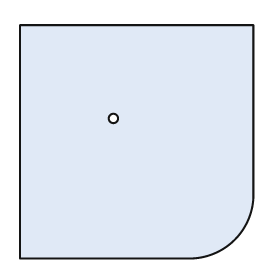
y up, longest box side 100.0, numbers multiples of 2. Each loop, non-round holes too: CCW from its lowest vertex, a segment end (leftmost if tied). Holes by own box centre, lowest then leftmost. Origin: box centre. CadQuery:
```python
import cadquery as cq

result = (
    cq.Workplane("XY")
    .moveTo(-50.0, -50.0)
    .lineTo(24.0, -50.0)
    .threePointArc((42.0, -42.0), (50.0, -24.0))
    .lineTo(50.0, 50.0)
    .lineTo(-50.0, 50.0)
    .close()
    .moveTo(-10.0, 10.0)
    .circle(2.0)
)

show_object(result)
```